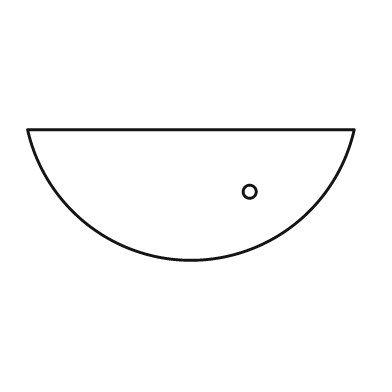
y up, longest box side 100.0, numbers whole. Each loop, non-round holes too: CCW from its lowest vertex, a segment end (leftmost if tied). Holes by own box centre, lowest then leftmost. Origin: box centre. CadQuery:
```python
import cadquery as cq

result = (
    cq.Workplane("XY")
    .moveTo(-50.0, 20.0)
    .threePointArc((0.0, -20.0), (50.0, 20.0))
    .close()
    .moveTo(18.0, 1.0)
    .circle(2.0)
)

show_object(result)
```